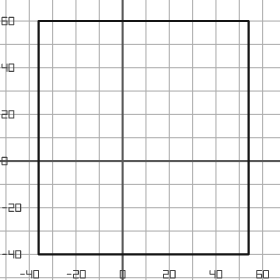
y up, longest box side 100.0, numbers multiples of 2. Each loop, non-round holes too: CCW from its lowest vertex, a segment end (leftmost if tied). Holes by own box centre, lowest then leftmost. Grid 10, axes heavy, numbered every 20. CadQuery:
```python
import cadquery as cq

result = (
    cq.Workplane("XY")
    .moveTo(-36.0, -40.0)
    .lineTo(54.0, -40.0)
    .lineTo(54.0, 60.0)
    .lineTo(-36.0, 60.0)
    .close()
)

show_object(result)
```